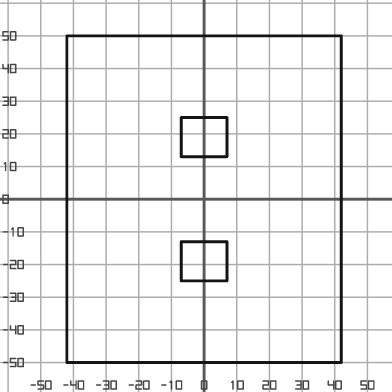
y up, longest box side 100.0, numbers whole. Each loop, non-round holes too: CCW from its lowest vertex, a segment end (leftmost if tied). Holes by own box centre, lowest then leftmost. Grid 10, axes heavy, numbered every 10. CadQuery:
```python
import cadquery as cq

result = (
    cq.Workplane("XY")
    .moveTo(-42.0, -50.0)
    .lineTo(42.0, -50.0)
    .lineTo(42.0, 50.0)
    .lineTo(-42.0, 50.0)
    .close()
    .moveTo(-7.0, -25.0)
    .lineTo(7.0, -25.0)
    .lineTo(7.0, -13.0)
    .lineTo(-7.0, -13.0)
    .close()
    .moveTo(-7.0, 13.0)
    .lineTo(7.0, 13.0)
    .lineTo(7.0, 25.0)
    .lineTo(-7.0, 25.0)
    .close()
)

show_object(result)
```